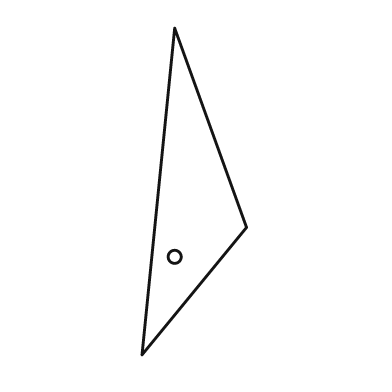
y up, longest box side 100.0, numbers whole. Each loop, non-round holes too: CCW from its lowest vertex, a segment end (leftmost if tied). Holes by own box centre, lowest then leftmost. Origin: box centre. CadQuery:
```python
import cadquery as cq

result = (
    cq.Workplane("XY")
    .moveTo(-16.0, -50.0)
    .lineTo(16.0, -11.0)
    .lineTo(-6.0, 50.0)
    .close()
    .moveTo(-6.0, -20.0)
    .circle(2.0)
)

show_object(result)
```